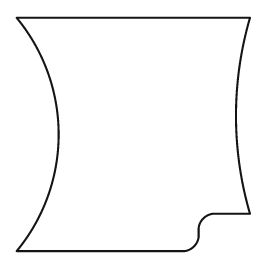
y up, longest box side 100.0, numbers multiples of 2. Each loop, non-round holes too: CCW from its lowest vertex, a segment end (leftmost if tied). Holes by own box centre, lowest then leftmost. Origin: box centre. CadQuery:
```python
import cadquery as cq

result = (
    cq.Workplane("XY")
    .moveTo(-50.0, -50.0)
    .lineTo(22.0, -50.0)
    .threePointArc((26.0, -48.0), (28.0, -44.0))
    .lineTo(28.0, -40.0)
    .threePointArc((30.0, -36.0), (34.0, -34.0))
    .lineTo(50.0, -34.0)
    .threePointArc((44.0, 8.0), (50.0, 50.0))
    .lineTo(-50.0, 50.0)
    .threePointArc((-32.0, 0.0), (-50.0, -50.0))
    .close()
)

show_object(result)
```